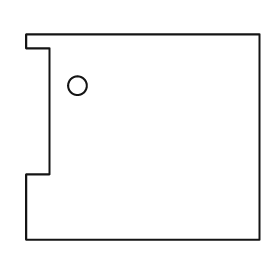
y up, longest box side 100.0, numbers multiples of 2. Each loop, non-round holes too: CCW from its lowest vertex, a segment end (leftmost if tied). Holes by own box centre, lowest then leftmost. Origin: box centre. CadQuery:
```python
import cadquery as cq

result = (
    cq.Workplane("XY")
    .moveTo(-50.0, -44.0)
    .lineTo(50.0, -44.0)
    .lineTo(50.0, 44.0)
    .lineTo(-50.0, 44.0)
    .lineTo(-50.0, 38.0)
    .lineTo(-40.0, 38.0)
    .lineTo(-40.0, -16.0)
    .lineTo(-50.0, -16.0)
    .close()
    .moveTo(-28.0, 22.0)
    .circle(4.0)
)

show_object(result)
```